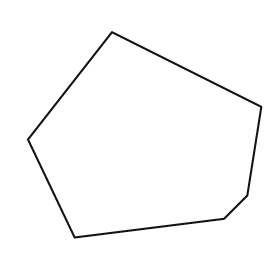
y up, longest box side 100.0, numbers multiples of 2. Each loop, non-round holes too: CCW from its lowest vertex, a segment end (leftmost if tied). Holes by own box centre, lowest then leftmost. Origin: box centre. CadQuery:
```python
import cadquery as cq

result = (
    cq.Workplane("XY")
    .moveTo(-30.0, -44.0)
    .lineTo(34.0, -36.0)
    .lineTo(44.0, -26.0)
    .lineTo(50.0, 12.0)
    .lineTo(-14.0, 44.0)
    .lineTo(-50.0, -2.0)
    .close()
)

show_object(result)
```